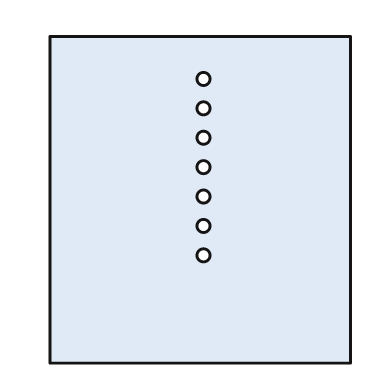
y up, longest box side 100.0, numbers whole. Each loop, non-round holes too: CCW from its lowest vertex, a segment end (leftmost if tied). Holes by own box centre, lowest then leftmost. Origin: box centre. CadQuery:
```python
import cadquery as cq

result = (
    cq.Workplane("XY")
    .moveTo(-46.0, -50.0)
    .lineTo(46.0, -50.0)
    .lineTo(46.0, 50.0)
    .lineTo(-46.0, 50.0)
    .close()
    .moveTo(1.0, -17.0)
    .circle(2.0)
    .moveTo(1.0, -8.0)
    .circle(2.0)
    .moveTo(1.0, 1.0)
    .circle(2.0)
    .moveTo(1.0, 10.0)
    .circle(2.0)
    .moveTo(1.0, 19.0)
    .circle(2.0)
    .moveTo(1.0, 28.0)
    .circle(2.0)
    .moveTo(1.0, 37.0)
    .circle(2.0)
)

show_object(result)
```